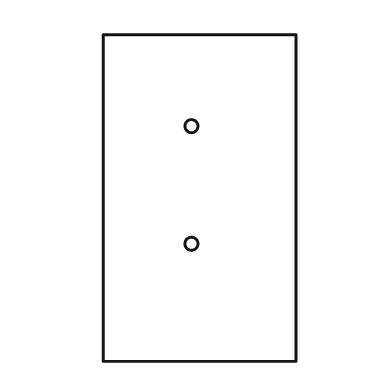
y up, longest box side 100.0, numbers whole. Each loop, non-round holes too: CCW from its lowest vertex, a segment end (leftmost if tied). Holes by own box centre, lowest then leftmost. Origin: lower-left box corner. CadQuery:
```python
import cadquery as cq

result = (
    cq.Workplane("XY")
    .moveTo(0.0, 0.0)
    .lineTo(59.0, 0.0)
    .lineTo(59.0, 100.0)
    .lineTo(0.0, 100.0)
    .close()
    .moveTo(27.0, 36.0)
    .circle(2.0)
    .moveTo(27.0, 72.0)
    .circle(2.0)
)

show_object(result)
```